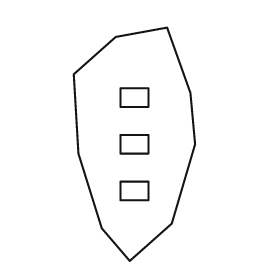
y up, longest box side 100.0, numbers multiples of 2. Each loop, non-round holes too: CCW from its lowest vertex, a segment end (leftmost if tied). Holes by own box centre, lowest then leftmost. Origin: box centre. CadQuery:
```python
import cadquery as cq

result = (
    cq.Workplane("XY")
    .moveTo(-2.0, -50.0)
    .lineTo(16.0, -34.0)
    .lineTo(26.0, 0.0)
    .lineTo(24.0, 22.0)
    .lineTo(14.0, 50.0)
    .lineTo(-8.0, 46.0)
    .lineTo(-26.0, 30.0)
    .lineTo(-24.0, -4.0)
    .lineTo(-14.0, -36.0)
    .close()
    .moveTo(-6.0, -24.0)
    .lineTo(6.0, -24.0)
    .lineTo(6.0, -16.0)
    .lineTo(-6.0, -16.0)
    .close()
    .moveTo(-6.0, -4.0)
    .lineTo(6.0, -4.0)
    .lineTo(6.0, 4.0)
    .lineTo(-6.0, 4.0)
    .close()
    .moveTo(-6.0, 16.0)
    .lineTo(6.0, 16.0)
    .lineTo(6.0, 24.0)
    .lineTo(-6.0, 24.0)
    .close()
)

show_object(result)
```